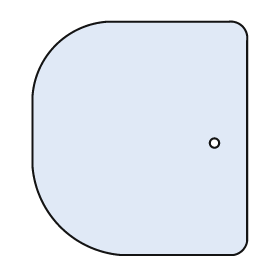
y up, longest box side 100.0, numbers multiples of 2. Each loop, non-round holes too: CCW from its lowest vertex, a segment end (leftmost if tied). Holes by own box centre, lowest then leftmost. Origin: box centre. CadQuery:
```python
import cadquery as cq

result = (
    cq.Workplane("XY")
    .moveTo(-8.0, -50.0)
    .lineTo(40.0, -50.0)
    .threePointArc((44.0, -48.0), (46.0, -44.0))
    .lineTo(46.0, 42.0)
    .threePointArc((44.0, 48.0), (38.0, 50.0))
    .lineTo(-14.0, 50.0)
    .threePointArc((-36.0, 40.0), (-46.0, 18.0))
    .lineTo(-46.0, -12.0)
    .threePointArc((-34.0, -38.0), (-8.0, -50.0))
    .close()
    .moveTo(32.0, -2.0)
    .circle(2.0)
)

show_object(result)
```